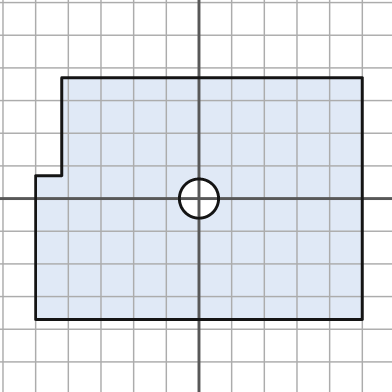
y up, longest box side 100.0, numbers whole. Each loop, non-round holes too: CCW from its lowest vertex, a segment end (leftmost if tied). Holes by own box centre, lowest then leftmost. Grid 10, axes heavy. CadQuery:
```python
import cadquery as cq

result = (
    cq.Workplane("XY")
    .moveTo(-50.0, -37.0)
    .lineTo(50.0, -37.0)
    .lineTo(50.0, 37.0)
    .lineTo(-42.0, 37.0)
    .lineTo(-42.0, 7.0)
    .lineTo(-50.0, 7.0)
    .close()
    .moveTo(0.0, 0.0)
    .circle(6.0)
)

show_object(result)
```